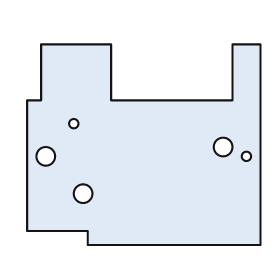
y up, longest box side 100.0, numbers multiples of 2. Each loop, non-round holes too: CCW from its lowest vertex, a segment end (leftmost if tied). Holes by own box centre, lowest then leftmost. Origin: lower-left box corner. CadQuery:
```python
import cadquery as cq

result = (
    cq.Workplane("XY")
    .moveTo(26.0, 0.0)
    .lineTo(100.0, 0.0)
    .lineTo(100.0, 86.0)
    .lineTo(88.0, 86.0)
    .lineTo(88.0, 62.0)
    .lineTo(36.0, 62.0)
    .lineTo(36.0, 86.0)
    .lineTo(6.0, 86.0)
    .lineTo(6.0, 62.0)
    .lineTo(0.0, 62.0)
    .lineTo(0.0, 6.0)
    .lineTo(26.0, 6.0)
    .close()
    .moveTo(24.0, 22.0)
    .circle(4.0)
    .moveTo(8.0, 38.0)
    .circle(4.0)
    .moveTo(94.0, 38.0)
    .circle(2.0)
    .moveTo(84.0, 42.0)
    .circle(4.0)
    .moveTo(20.0, 52.0)
    .circle(2.0)
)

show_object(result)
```